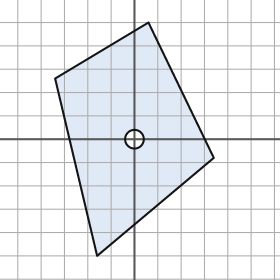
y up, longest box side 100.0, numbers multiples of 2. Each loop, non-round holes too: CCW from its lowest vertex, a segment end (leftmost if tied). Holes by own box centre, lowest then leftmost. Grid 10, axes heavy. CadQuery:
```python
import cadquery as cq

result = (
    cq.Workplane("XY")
    .moveTo(-16.0, -50.0)
    .lineTo(34.0, -8.0)
    .lineTo(6.0, 50.0)
    .lineTo(-34.0, 26.0)
    .close()
    .moveTo(0.0, 0.0)
    .circle(4.0)
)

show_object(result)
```